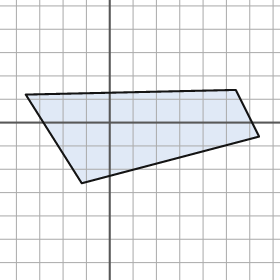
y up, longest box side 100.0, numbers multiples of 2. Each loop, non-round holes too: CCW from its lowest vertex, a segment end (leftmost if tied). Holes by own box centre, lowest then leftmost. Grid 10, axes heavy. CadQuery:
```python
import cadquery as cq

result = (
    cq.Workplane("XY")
    .moveTo(-12.0, -26.0)
    .lineTo(64.0, -6.0)
    .lineTo(54.0, 14.0)
    .lineTo(-36.0, 12.0)
    .close()
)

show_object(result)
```